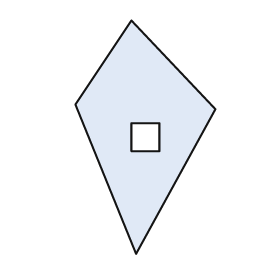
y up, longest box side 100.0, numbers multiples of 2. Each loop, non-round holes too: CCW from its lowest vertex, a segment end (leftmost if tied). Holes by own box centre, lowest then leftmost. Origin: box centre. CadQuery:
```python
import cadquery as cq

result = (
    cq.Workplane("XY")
    .moveTo(-4.0, -50.0)
    .lineTo(30.0, 12.0)
    .lineTo(-6.0, 50.0)
    .lineTo(-30.0, 14.0)
    .close()
    .moveTo(-6.0, -6.0)
    .lineTo(6.0, -6.0)
    .lineTo(6.0, 6.0)
    .lineTo(-6.0, 6.0)
    .close()
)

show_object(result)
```